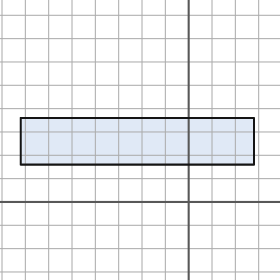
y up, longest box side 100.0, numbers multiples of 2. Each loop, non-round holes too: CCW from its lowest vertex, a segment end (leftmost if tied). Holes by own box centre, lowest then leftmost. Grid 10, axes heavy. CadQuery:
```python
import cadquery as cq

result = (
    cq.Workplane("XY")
    .moveTo(-72.0, 16.0)
    .lineTo(28.0, 16.0)
    .lineTo(28.0, 36.0)
    .lineTo(-72.0, 36.0)
    .close()
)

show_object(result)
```